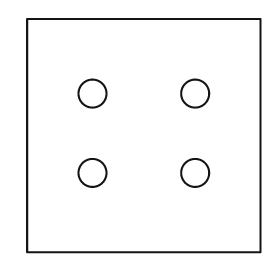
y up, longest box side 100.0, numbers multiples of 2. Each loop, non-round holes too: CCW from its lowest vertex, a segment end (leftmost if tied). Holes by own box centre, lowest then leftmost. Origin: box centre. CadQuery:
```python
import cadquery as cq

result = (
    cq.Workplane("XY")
    .moveTo(-50.0, -50.0)
    .lineTo(50.0, -50.0)
    .lineTo(50.0, 50.0)
    .lineTo(-50.0, 50.0)
    .close()
    .moveTo(-22.0, -16.0)
    .circle(6.0)
    .moveTo(22.0, -16.0)
    .circle(6.0)
    .moveTo(-22.0, 18.0)
    .circle(6.0)
    .moveTo(22.0, 18.0)
    .circle(6.0)
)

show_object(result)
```